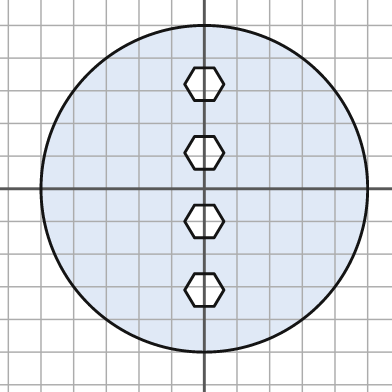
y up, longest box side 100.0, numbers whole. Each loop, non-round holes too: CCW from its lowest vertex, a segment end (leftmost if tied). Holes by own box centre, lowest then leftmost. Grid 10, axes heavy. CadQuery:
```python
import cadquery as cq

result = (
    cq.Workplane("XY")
    .moveTo(0.0, 0.0)
    .circle(50.0)
    .moveTo(-3.0, -36.0)
    .lineTo(3.0, -36.0)
    .lineTo(6.0, -31.0)
    .lineTo(3.0, -26.0)
    .lineTo(-3.0, -26.0)
    .lineTo(-6.0, -31.0)
    .close()
    .moveTo(-3.0, -15.0)
    .lineTo(3.0, -15.0)
    .lineTo(6.0, -10.0)
    .lineTo(3.0, -5.0)
    .lineTo(-3.0, -5.0)
    .lineTo(-6.0, -10.0)
    .close()
    .moveTo(-3.0, 6.0)
    .lineTo(3.0, 6.0)
    .lineTo(6.0, 11.0)
    .lineTo(3.0, 16.0)
    .lineTo(-3.0, 16.0)
    .lineTo(-6.0, 11.0)
    .close()
    .moveTo(-3.0, 27.0)
    .lineTo(3.0, 27.0)
    .lineTo(6.0, 32.0)
    .lineTo(3.0, 37.0)
    .lineTo(-3.0, 37.0)
    .lineTo(-6.0, 32.0)
    .close()
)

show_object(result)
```